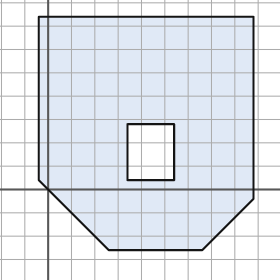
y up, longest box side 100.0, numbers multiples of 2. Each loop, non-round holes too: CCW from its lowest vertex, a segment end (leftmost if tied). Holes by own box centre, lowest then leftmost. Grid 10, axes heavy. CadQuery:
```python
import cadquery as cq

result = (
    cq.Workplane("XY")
    .moveTo(26.0, -26.0)
    .lineTo(66.0, -26.0)
    .lineTo(88.0, -4.0)
    .lineTo(88.0, 74.0)
    .lineTo(-4.0, 74.0)
    .lineTo(-4.0, 4.0)
    .close()
    .moveTo(34.0, 4.0)
    .lineTo(54.0, 4.0)
    .lineTo(54.0, 28.0)
    .lineTo(34.0, 28.0)
    .close()
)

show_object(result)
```